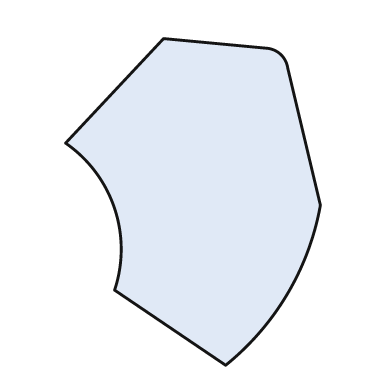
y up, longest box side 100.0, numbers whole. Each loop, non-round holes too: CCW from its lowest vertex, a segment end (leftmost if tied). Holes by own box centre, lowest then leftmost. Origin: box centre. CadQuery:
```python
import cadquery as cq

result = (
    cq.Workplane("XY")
    .moveTo(10.0, -50.0)
    .threePointArc((29.0, -28.0), (39.0, -1.0))
    .lineTo(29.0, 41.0)
    .threePointArc((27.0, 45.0), (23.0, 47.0))
    .lineTo(-9.0, 50.0)
    .lineTo(-39.0, 18.0)
    .threePointArc((-24.0, -2.0), (-24.0, -27.0))
    .close()
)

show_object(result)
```